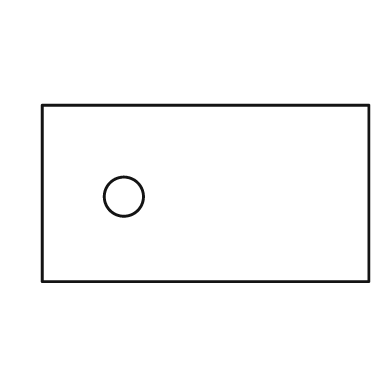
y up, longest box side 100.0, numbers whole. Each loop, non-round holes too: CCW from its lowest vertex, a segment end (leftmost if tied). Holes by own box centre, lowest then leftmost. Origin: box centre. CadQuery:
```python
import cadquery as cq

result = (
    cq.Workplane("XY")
    .moveTo(-50.0, -27.0)
    .lineTo(50.0, -27.0)
    .lineTo(50.0, 27.0)
    .lineTo(-50.0, 27.0)
    .close()
    .moveTo(-25.0, -1.0)
    .circle(6.0)
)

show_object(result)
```